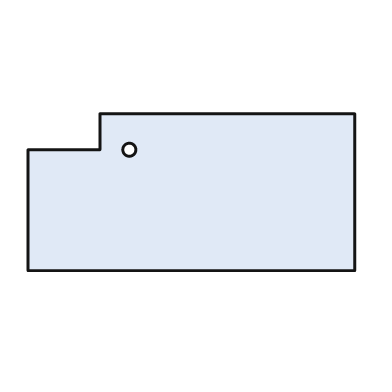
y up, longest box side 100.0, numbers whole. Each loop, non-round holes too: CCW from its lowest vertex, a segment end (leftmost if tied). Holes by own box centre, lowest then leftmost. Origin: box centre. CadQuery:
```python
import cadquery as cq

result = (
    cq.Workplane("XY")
    .moveTo(-50.0, -24.0)
    .lineTo(50.0, -24.0)
    .lineTo(50.0, 24.0)
    .lineTo(-28.0, 24.0)
    .lineTo(-28.0, 13.0)
    .lineTo(-50.0, 13.0)
    .close()
    .moveTo(-19.0, 13.0)
    .circle(2.0)
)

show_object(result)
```